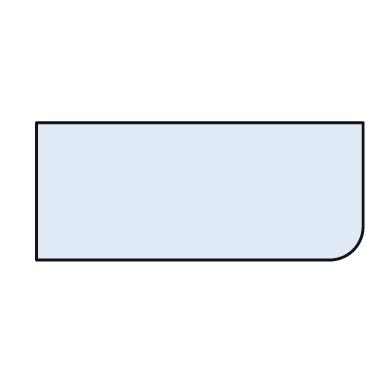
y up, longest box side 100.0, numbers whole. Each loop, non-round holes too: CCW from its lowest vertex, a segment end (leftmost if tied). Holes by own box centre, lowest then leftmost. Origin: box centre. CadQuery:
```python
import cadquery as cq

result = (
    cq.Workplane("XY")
    .moveTo(-50.0, -21.0)
    .lineTo(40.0, -21.0)
    .threePointArc((47.0, -18.0), (50.0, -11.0))
    .lineTo(50.0, 21.0)
    .lineTo(-50.0, 21.0)
    .close()
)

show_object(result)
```